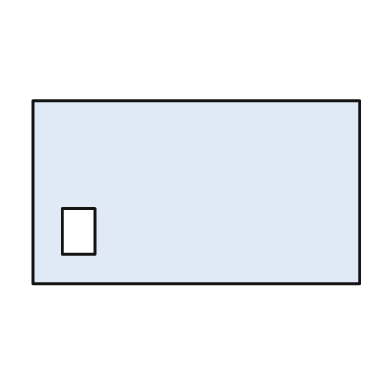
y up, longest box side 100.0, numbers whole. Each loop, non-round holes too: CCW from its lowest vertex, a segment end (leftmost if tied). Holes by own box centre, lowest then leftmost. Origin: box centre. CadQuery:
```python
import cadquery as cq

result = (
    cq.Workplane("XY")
    .moveTo(-50.0, -28.0)
    .lineTo(50.0, -28.0)
    .lineTo(50.0, 28.0)
    .lineTo(-50.0, 28.0)
    .close()
    .moveTo(-41.0, -19.0)
    .lineTo(-31.0, -19.0)
    .lineTo(-31.0, -5.0)
    .lineTo(-41.0, -5.0)
    .close()
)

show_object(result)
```